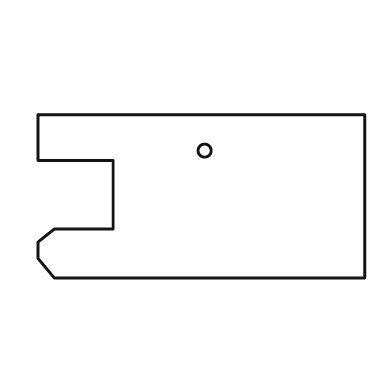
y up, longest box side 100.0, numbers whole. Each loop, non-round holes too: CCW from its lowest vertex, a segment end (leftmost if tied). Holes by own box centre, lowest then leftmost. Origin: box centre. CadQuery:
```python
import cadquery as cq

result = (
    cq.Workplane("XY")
    .moveTo(-45.0, -25.0)
    .lineTo(50.0, -25.0)
    .lineTo(50.0, 25.0)
    .lineTo(-50.0, 25.0)
    .lineTo(-50.0, 11.0)
    .lineTo(-27.0, 11.0)
    .lineTo(-27.0, -10.0)
    .lineTo(-45.0, -10.0)
    .lineTo(-50.0, -14.0)
    .lineTo(-50.0, -19.0)
    .close()
    .moveTo(1.0, 14.0)
    .circle(2.0)
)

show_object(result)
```